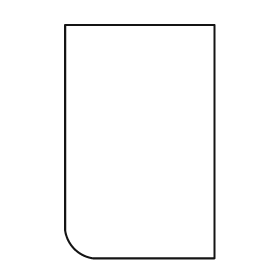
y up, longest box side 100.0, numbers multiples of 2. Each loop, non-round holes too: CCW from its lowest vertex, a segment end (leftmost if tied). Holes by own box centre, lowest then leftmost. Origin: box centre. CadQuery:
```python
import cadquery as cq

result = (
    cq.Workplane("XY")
    .moveTo(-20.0, -50.0)
    .lineTo(32.0, -50.0)
    .lineTo(32.0, 50.0)
    .lineTo(-32.0, 50.0)
    .lineTo(-32.0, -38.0)
    .threePointArc((-28.0, -46.0), (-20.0, -50.0))
    .close()
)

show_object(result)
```